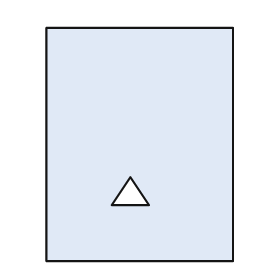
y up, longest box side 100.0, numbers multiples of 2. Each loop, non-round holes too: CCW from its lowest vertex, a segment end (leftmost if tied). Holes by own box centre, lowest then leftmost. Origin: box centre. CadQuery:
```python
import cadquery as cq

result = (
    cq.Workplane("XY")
    .moveTo(-40.0, -50.0)
    .lineTo(40.0, -50.0)
    .lineTo(40.0, 50.0)
    .lineTo(-40.0, 50.0)
    .close()
    .moveTo(-12.0, -26.0)
    .lineTo(4.0, -26.0)
    .lineTo(-4.0, -14.0)
    .close()
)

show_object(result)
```